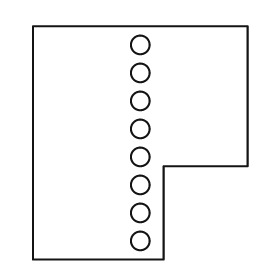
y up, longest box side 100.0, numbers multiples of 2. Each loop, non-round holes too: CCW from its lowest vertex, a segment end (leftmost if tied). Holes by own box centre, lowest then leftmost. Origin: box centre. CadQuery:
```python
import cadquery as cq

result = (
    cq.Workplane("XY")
    .moveTo(-46.0, -50.0)
    .lineTo(10.0, -50.0)
    .lineTo(10.0, -10.0)
    .lineTo(46.0, -10.0)
    .lineTo(46.0, 50.0)
    .lineTo(-46.0, 50.0)
    .close()
    .moveTo(0.0, -42.0)
    .circle(4.0)
    .moveTo(0.0, -30.0)
    .circle(4.0)
    .moveTo(0.0, -18.0)
    .circle(4.0)
    .moveTo(0.0, -6.0)
    .circle(4.0)
    .moveTo(0.0, 6.0)
    .circle(4.0)
    .moveTo(0.0, 18.0)
    .circle(4.0)
    .moveTo(0.0, 30.0)
    .circle(4.0)
    .moveTo(0.0, 42.0)
    .circle(4.0)
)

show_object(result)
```